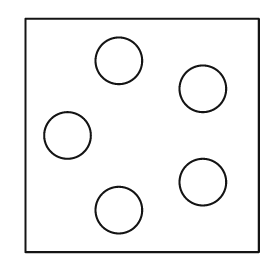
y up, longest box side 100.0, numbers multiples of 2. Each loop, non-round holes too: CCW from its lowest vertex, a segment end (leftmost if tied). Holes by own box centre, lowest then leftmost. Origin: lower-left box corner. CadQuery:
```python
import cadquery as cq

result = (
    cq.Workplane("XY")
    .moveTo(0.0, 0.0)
    .lineTo(100.0, 0.0)
    .lineTo(100.0, 100.0)
    .lineTo(0.0, 100.0)
    .close()
    .moveTo(40.0, 18.0)
    .circle(10.0)
    .moveTo(76.0, 30.0)
    .circle(10.0)
    .moveTo(18.0, 50.0)
    .circle(10.0)
    .moveTo(76.0, 70.0)
    .circle(10.0)
    .moveTo(40.0, 82.0)
    .circle(10.0)
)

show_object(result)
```